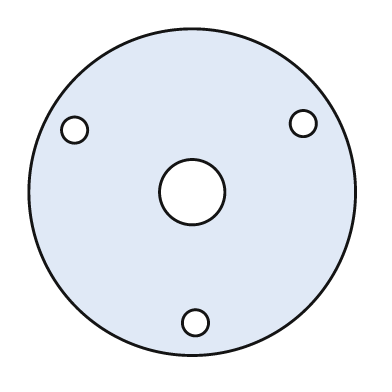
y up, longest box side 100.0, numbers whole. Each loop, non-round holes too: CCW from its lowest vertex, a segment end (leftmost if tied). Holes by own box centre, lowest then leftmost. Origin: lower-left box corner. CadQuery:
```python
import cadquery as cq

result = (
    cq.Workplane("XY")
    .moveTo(50.0, 50.0)
    .circle(50.0)
    .moveTo(51.0, 10.0)
    .circle(4.0)
    .moveTo(50.0, 50.0)
    .circle(10.0)
    .moveTo(14.0, 69.0)
    .circle(4.0)
    .moveTo(84.0, 71.0)
    .circle(4.0)
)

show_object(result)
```